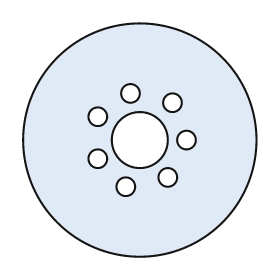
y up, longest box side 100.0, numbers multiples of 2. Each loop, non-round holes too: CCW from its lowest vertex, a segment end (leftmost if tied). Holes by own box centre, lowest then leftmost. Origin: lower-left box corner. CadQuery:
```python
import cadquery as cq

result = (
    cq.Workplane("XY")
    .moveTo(50.0, 50.0)
    .circle(50.0)
    .moveTo(44.0, 30.0)
    .circle(4.0)
    .moveTo(62.0, 34.0)
    .circle(4.0)
    .moveTo(32.0, 42.0)
    .circle(4.0)
    .moveTo(50.0, 50.0)
    .circle(12.0)
    .moveTo(70.0, 50.0)
    .circle(4.0)
    .moveTo(32.0, 60.0)
    .circle(4.0)
    .moveTo(64.0, 66.0)
    .circle(4.0)
    .moveTo(46.0, 70.0)
    .circle(4.0)
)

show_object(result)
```